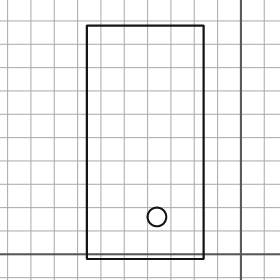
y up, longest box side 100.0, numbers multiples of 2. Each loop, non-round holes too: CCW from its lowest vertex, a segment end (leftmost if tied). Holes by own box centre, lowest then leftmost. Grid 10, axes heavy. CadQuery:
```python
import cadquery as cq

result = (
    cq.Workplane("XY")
    .moveTo(-66.0, -2.0)
    .lineTo(-16.0, -2.0)
    .lineTo(-16.0, 98.0)
    .lineTo(-66.0, 98.0)
    .close()
    .moveTo(-36.0, 16.0)
    .circle(4.0)
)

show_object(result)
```